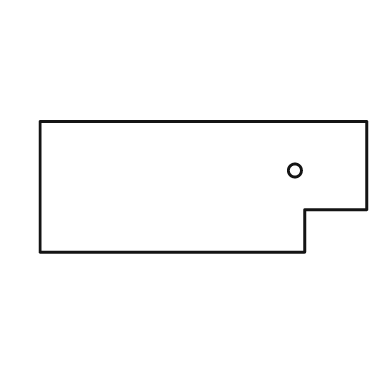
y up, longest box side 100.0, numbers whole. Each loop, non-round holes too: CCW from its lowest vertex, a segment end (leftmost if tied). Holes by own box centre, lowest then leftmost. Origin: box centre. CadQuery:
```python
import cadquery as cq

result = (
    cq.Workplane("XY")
    .moveTo(-50.0, -20.0)
    .lineTo(31.0, -20.0)
    .lineTo(31.0, -7.0)
    .lineTo(50.0, -7.0)
    .lineTo(50.0, 20.0)
    .lineTo(-50.0, 20.0)
    .close()
    .moveTo(28.0, 5.0)
    .circle(2.0)
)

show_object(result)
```